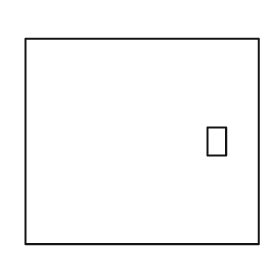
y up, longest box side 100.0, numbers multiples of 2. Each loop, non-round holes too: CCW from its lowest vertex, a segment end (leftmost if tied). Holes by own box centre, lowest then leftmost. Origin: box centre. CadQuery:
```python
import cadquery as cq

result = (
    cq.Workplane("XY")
    .moveTo(-50.0, -44.0)
    .lineTo(50.0, -44.0)
    .lineTo(50.0, 44.0)
    .lineTo(-50.0, 44.0)
    .close()
    .moveTo(28.0, -6.0)
    .lineTo(36.0, -6.0)
    .lineTo(36.0, 6.0)
    .lineTo(28.0, 6.0)
    .close()
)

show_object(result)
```